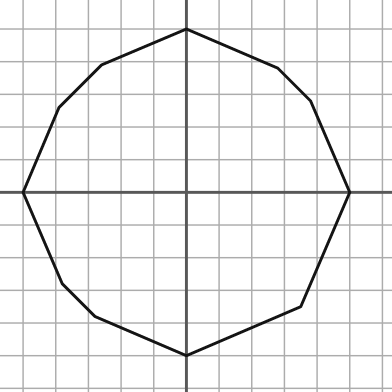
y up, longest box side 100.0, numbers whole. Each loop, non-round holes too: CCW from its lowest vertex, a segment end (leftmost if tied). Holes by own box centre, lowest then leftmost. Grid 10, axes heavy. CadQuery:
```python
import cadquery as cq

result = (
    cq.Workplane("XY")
    .moveTo(0.0, -50.0)
    .lineTo(35.0, -35.0)
    .lineTo(50.0, 0.0)
    .lineTo(38.0, 28.0)
    .lineTo(28.0, 38.0)
    .lineTo(0.0, 50.0)
    .lineTo(-26.0, 39.0)
    .lineTo(-39.0, 26.0)
    .lineTo(-50.0, 0.0)
    .lineTo(-38.0, -28.0)
    .lineTo(-28.0, -38.0)
    .close()
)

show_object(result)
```